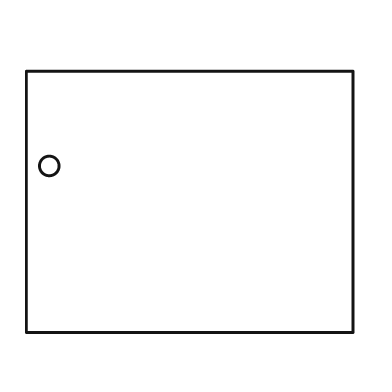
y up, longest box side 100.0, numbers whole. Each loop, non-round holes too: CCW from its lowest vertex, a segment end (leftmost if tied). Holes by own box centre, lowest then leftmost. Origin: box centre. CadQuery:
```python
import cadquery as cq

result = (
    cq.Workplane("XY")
    .moveTo(-50.0, -40.0)
    .lineTo(50.0, -40.0)
    .lineTo(50.0, 40.0)
    .lineTo(-50.0, 40.0)
    .close()
    .moveTo(-43.0, 11.0)
    .circle(3.0)
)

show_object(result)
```